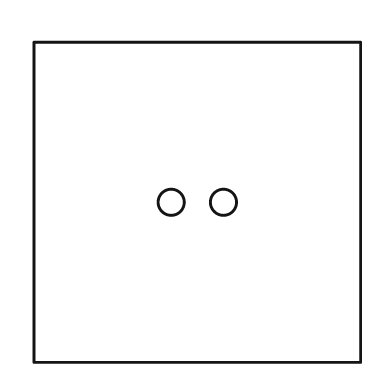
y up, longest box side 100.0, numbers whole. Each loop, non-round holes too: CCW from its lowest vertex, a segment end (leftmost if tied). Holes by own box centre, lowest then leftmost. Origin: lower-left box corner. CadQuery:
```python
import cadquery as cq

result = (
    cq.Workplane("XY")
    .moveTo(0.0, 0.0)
    .lineTo(100.0, 0.0)
    .lineTo(100.0, 98.0)
    .lineTo(0.0, 98.0)
    .close()
    .moveTo(42.0, 49.0)
    .circle(4.0)
    .moveTo(58.0, 49.0)
    .circle(4.0)
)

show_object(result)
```